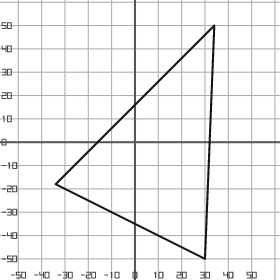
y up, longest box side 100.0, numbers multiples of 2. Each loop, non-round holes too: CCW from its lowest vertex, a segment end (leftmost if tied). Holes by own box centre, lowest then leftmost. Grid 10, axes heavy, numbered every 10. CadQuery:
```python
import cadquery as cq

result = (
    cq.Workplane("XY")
    .moveTo(30.0, -50.0)
    .lineTo(34.0, 50.0)
    .lineTo(-34.0, -18.0)
    .close()
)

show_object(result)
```